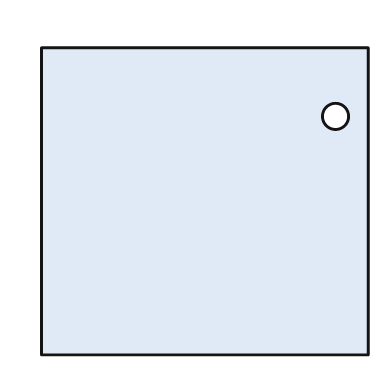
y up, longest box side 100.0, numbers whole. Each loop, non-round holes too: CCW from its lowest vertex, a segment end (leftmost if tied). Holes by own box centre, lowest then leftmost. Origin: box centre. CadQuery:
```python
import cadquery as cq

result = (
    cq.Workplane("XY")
    .moveTo(-50.0, -47.0)
    .lineTo(50.0, -47.0)
    .lineTo(50.0, 47.0)
    .lineTo(-50.0, 47.0)
    .close()
    .moveTo(40.0, 26.0)
    .circle(4.0)
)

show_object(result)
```